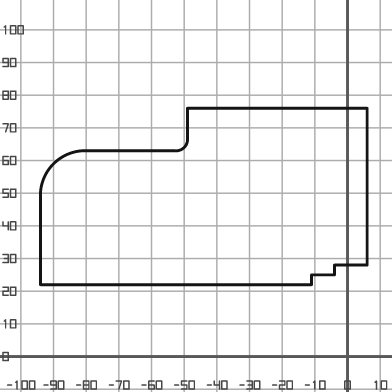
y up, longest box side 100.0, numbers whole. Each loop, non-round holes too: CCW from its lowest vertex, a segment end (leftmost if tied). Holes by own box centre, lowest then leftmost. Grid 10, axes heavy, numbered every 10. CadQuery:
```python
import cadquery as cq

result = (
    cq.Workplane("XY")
    .moveTo(-94.0, 22.0)
    .lineTo(-11.0, 22.0)
    .lineTo(-11.0, 25.0)
    .lineTo(-4.0, 25.0)
    .lineTo(-4.0, 28.0)
    .lineTo(6.0, 28.0)
    .lineTo(6.0, 76.0)
    .lineTo(-49.0, 76.0)
    .lineTo(-49.0, 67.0)
    .threePointArc((-50.0, 64.0), (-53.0, 63.0))
    .lineTo(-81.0, 63.0)
    .threePointArc((-90.0, 59.0), (-94.0, 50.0))
    .close()
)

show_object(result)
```